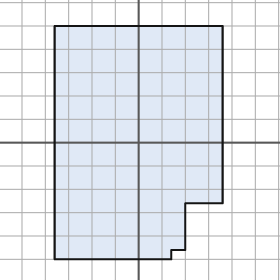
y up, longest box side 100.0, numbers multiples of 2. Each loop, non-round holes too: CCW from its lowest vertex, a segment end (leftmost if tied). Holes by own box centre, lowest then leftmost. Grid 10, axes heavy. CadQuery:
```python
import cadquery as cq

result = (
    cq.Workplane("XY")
    .moveTo(-36.0, -50.0)
    .lineTo(14.0, -50.0)
    .lineTo(14.0, -46.0)
    .lineTo(20.0, -46.0)
    .lineTo(20.0, -26.0)
    .lineTo(36.0, -26.0)
    .lineTo(36.0, 50.0)
    .lineTo(-36.0, 50.0)
    .close()
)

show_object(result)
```